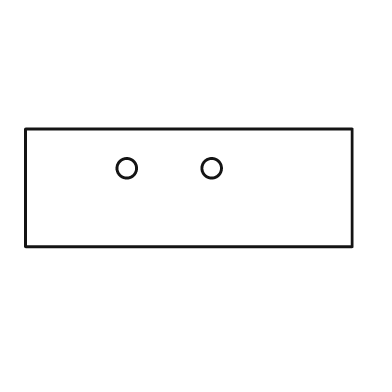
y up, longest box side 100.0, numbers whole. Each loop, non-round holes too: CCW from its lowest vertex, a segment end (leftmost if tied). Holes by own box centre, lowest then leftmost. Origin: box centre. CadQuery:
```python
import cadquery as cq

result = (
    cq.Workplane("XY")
    .moveTo(-50.0, -18.0)
    .lineTo(50.0, -18.0)
    .lineTo(50.0, 18.0)
    .lineTo(-50.0, 18.0)
    .close()
    .moveTo(-19.0, 6.0)
    .circle(3.0)
    .moveTo(7.0, 6.0)
    .circle(3.0)
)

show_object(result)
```